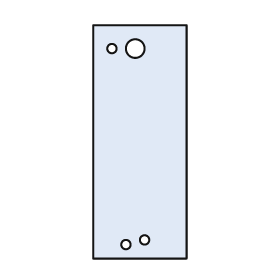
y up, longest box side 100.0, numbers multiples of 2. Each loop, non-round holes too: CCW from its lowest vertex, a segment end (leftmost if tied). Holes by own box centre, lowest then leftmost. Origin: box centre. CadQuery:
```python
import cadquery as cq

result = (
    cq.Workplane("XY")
    .moveTo(-20.0, -50.0)
    .lineTo(20.0, -50.0)
    .lineTo(20.0, 50.0)
    .lineTo(-20.0, 50.0)
    .close()
    .moveTo(-6.0, -44.0)
    .circle(2.0)
    .moveTo(2.0, -42.0)
    .circle(2.0)
    .moveTo(-12.0, 40.0)
    .circle(2.0)
    .moveTo(-2.0, 40.0)
    .circle(4.0)
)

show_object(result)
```